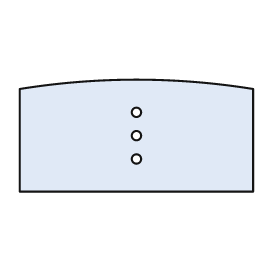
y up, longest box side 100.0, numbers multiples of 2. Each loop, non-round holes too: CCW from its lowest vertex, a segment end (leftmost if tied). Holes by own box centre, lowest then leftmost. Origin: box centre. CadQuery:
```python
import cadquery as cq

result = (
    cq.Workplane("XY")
    .moveTo(-50.0, -24.0)
    .lineTo(50.0, -24.0)
    .lineTo(50.0, 20.0)
    .threePointArc((0.0, 24.0), (-50.0, 20.0))
    .close()
    .moveTo(0.0, -10.0)
    .circle(2.0)
    .moveTo(0.0, 0.0)
    .circle(2.0)
    .moveTo(0.0, 10.0)
    .circle(2.0)
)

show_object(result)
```